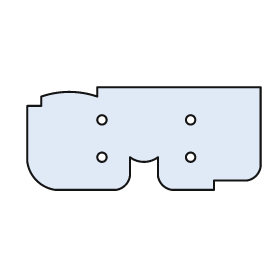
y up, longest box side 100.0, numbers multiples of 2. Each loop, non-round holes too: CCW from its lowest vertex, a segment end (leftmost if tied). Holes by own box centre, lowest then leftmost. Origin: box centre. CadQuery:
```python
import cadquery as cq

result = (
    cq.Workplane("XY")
    .moveTo(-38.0, -22.0)
    .lineTo(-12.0, -22.0)
    .threePointArc((-8.0, -20.0), (-6.0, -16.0))
    .lineTo(-6.0, -8.0)
    .threePointArc((0.0, -10.0), (6.0, -8.0))
    .lineTo(6.0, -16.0)
    .threePointArc((8.0, -20.0), (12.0, -22.0))
    .lineTo(30.0, -22.0)
    .lineTo(30.0, -18.0)
    .lineTo(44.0, -18.0)
    .threePointArc((48.0, -16.0), (50.0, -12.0))
    .lineTo(50.0, 22.0)
    .lineTo(-20.0, 22.0)
    .lineTo(-20.0, 18.0)
    .threePointArc((-32.0, 20.0), (-44.0, 18.0))
    .lineTo(-44.0, 14.0)
    .lineTo(-50.0, 14.0)
    .lineTo(-50.0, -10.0)
    .threePointArc((-46.0, -18.0), (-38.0, -22.0))
    .close()
    .moveTo(-18.0, -8.0)
    .circle(2.0)
    .moveTo(20.0, -8.0)
    .circle(2.0)
    .moveTo(-18.0, 8.0)
    .circle(2.0)
    .moveTo(20.0, 8.0)
    .circle(2.0)
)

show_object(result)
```